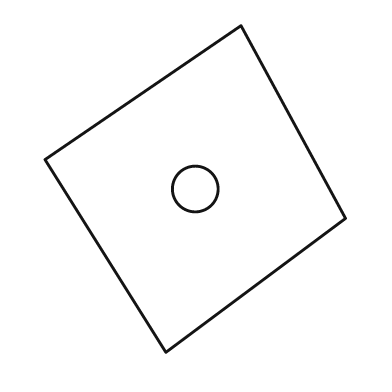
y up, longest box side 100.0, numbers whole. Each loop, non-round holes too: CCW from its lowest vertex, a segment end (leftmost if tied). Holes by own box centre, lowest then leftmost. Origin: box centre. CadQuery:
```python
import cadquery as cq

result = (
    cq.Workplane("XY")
    .moveTo(-9.0, -50.0)
    .lineTo(46.0, -9.0)
    .lineTo(14.0, 50.0)
    .lineTo(-46.0, 9.0)
    .close()
    .moveTo(0.0, 0.0)
    .circle(7.0)
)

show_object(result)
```